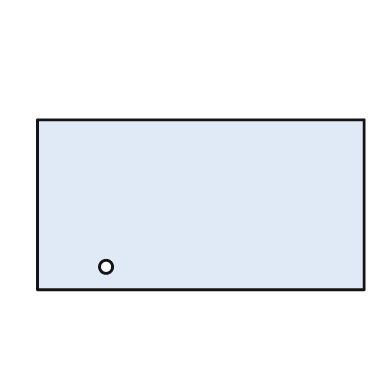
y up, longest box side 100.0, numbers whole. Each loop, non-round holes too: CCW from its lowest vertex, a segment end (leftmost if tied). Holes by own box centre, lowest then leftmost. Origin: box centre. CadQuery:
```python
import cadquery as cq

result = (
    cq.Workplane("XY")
    .moveTo(-50.0, -26.0)
    .lineTo(50.0, -26.0)
    .lineTo(50.0, 26.0)
    .lineTo(-50.0, 26.0)
    .close()
    .moveTo(-29.0, -19.0)
    .circle(2.0)
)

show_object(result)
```